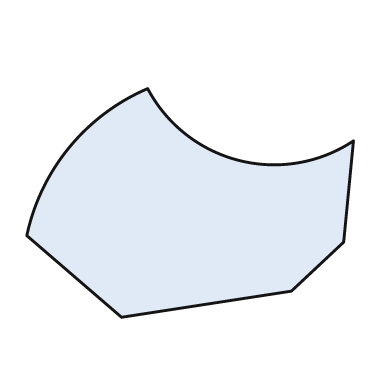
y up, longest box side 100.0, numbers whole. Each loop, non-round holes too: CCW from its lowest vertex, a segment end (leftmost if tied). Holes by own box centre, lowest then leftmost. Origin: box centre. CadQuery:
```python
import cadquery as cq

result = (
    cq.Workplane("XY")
    .moveTo(-21.0, -35.0)
    .lineTo(31.0, -27.0)
    .lineTo(47.0, -12.0)
    .lineTo(50.0, 19.0)
    .threePointArc((15.0, 13.0), (-13.0, 35.0))
    .threePointArc((-37.0, 17.0), (-50.0, -10.0))
    .close()
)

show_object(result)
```